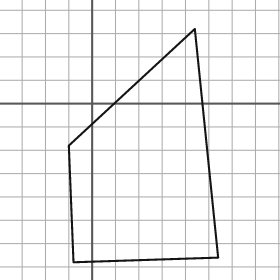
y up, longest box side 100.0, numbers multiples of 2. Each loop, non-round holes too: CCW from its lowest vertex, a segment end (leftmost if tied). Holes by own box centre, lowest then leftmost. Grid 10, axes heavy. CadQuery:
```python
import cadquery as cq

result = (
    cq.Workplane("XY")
    .moveTo(-8.0, -68.0)
    .lineTo(54.0, -66.0)
    .lineTo(44.0, 32.0)
    .lineTo(-10.0, -18.0)
    .close()
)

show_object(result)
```